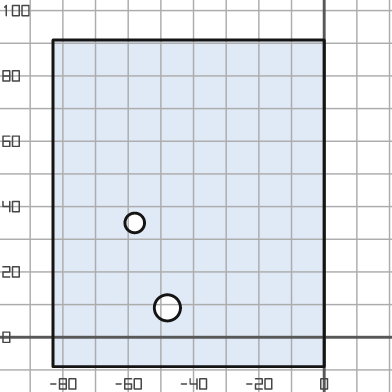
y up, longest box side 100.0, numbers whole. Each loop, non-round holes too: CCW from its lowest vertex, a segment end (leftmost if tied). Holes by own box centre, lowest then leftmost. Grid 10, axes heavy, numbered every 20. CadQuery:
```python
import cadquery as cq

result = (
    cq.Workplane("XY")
    .moveTo(-83.0, -9.0)
    .lineTo(0.0, -9.0)
    .lineTo(0.0, 91.0)
    .lineTo(-83.0, 91.0)
    .close()
    .moveTo(-48.0, 9.0)
    .circle(4.0)
    .moveTo(-58.0, 35.0)
    .circle(3.0)
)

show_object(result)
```